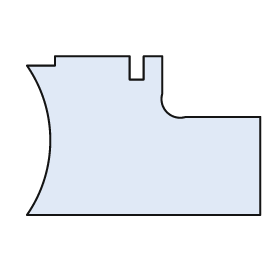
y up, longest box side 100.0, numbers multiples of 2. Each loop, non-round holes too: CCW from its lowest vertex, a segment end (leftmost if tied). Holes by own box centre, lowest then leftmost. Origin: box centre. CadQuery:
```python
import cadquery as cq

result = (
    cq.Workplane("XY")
    .moveTo(-50.0, -34.0)
    .lineTo(50.0, -34.0)
    .lineTo(50.0, 8.0)
    .lineTo(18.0, 8.0)
    .threePointArc((10.0, 10.0), (8.0, 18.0))
    .lineTo(8.0, 34.0)
    .lineTo(0.0, 34.0)
    .lineTo(0.0, 24.0)
    .lineTo(-6.0, 24.0)
    .lineTo(-6.0, 34.0)
    .lineTo(-38.0, 34.0)
    .lineTo(-38.0, 30.0)
    .lineTo(-50.0, 30.0)
    .threePointArc((-40.0, -2.0), (-50.0, -34.0))
    .close()
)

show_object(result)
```